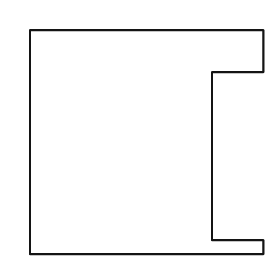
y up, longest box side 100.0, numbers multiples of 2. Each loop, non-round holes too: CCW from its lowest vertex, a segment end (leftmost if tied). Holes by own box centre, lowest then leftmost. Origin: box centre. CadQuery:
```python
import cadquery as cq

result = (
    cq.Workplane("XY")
    .moveTo(-50.0, -48.0)
    .lineTo(50.0, -48.0)
    .lineTo(50.0, -42.0)
    .lineTo(28.0, -42.0)
    .lineTo(28.0, 30.0)
    .lineTo(50.0, 30.0)
    .lineTo(50.0, 48.0)
    .lineTo(-50.0, 48.0)
    .close()
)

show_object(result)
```